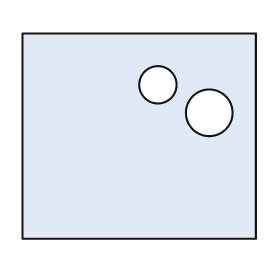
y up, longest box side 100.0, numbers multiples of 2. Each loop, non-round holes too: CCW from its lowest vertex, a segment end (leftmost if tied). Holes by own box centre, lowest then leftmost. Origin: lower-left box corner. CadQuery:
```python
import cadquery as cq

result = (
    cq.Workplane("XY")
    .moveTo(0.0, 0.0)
    .lineTo(100.0, 0.0)
    .lineTo(100.0, 88.0)
    .lineTo(0.0, 88.0)
    .close()
    .moveTo(80.0, 54.0)
    .circle(10.0)
    .moveTo(58.0, 66.0)
    .circle(8.0)
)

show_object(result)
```